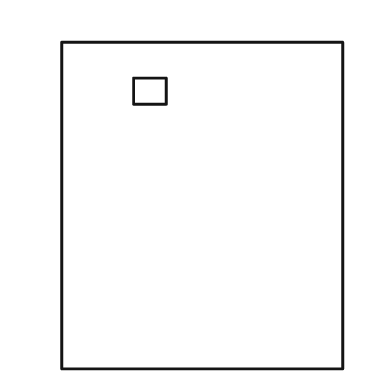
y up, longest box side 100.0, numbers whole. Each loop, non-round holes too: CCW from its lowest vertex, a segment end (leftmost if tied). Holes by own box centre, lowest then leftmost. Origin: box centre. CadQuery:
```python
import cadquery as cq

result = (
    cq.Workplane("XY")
    .moveTo(-43.0, -50.0)
    .lineTo(43.0, -50.0)
    .lineTo(43.0, 50.0)
    .lineTo(-43.0, 50.0)
    .close()
    .moveTo(-21.0, 31.0)
    .lineTo(-11.0, 31.0)
    .lineTo(-11.0, 39.0)
    .lineTo(-21.0, 39.0)
    .close()
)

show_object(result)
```